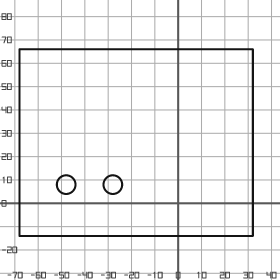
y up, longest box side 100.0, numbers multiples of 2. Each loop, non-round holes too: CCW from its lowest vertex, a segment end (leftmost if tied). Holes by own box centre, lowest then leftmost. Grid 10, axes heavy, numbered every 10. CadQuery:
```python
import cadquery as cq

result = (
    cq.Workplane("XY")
    .moveTo(-68.0, -14.0)
    .lineTo(32.0, -14.0)
    .lineTo(32.0, 66.0)
    .lineTo(-68.0, 66.0)
    .close()
    .moveTo(-48.0, 8.0)
    .circle(4.0)
    .moveTo(-28.0, 8.0)
    .circle(4.0)
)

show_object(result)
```